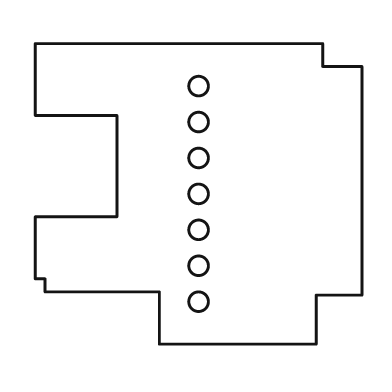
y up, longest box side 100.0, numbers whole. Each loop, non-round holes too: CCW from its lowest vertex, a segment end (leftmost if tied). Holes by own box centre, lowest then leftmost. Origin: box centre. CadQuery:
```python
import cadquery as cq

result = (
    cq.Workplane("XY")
    .moveTo(-12.0, -46.0)
    .lineTo(36.0, -46.0)
    .lineTo(36.0, -31.0)
    .lineTo(50.0, -31.0)
    .lineTo(50.0, 39.0)
    .lineTo(38.0, 39.0)
    .lineTo(38.0, 46.0)
    .lineTo(-50.0, 46.0)
    .lineTo(-50.0, 24.0)
    .lineTo(-25.0, 24.0)
    .lineTo(-25.0, -7.0)
    .lineTo(-50.0, -7.0)
    .lineTo(-50.0, -26.0)
    .lineTo(-47.0, -26.0)
    .lineTo(-47.0, -30.0)
    .lineTo(-12.0, -30.0)
    .close()
    .moveTo(0.0, -33.0)
    .circle(3.0)
    .moveTo(0.0, -22.0)
    .circle(3.0)
    .moveTo(0.0, -11.0)
    .circle(3.0)
    .moveTo(0.0, 0.0)
    .circle(3.0)
    .moveTo(0.0, 11.0)
    .circle(3.0)
    .moveTo(0.0, 22.0)
    .circle(3.0)
    .moveTo(0.0, 33.0)
    .circle(3.0)
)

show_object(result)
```